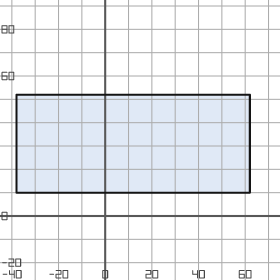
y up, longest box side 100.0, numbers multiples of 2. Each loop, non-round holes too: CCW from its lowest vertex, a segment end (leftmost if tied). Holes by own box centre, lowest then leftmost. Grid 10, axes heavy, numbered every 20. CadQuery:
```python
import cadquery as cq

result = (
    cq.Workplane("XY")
    .moveTo(-38.0, 10.0)
    .lineTo(62.0, 10.0)
    .lineTo(62.0, 52.0)
    .lineTo(-38.0, 52.0)
    .close()
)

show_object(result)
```